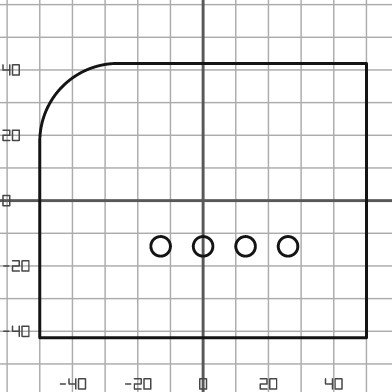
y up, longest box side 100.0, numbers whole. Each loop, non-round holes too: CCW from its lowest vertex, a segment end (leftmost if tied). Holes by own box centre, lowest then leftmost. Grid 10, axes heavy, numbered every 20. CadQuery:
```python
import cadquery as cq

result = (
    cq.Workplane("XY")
    .moveTo(-50.0, -42.0)
    .lineTo(50.0, -42.0)
    .lineTo(50.0, 42.0)
    .lineTo(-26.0, 42.0)
    .threePointArc((-43.0, 35.0), (-50.0, 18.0))
    .close()
    .moveTo(-13.0, -14.0)
    .circle(3.0)
    .moveTo(0.0, -14.0)
    .circle(3.0)
    .moveTo(13.0, -14.0)
    .circle(3.0)
    .moveTo(26.0, -14.0)
    .circle(3.0)
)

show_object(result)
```